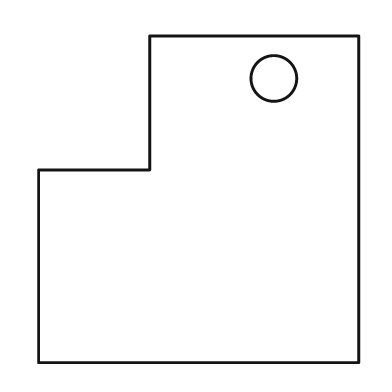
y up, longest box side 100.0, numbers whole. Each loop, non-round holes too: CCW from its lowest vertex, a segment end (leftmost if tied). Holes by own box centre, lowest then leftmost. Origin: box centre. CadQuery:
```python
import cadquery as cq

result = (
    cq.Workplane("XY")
    .moveTo(-49.0, -50.0)
    .lineTo(49.0, -50.0)
    .lineTo(49.0, 50.0)
    .lineTo(-15.0, 50.0)
    .lineTo(-15.0, 9.0)
    .lineTo(-49.0, 9.0)
    .close()
    .moveTo(23.0, 37.0)
    .circle(7.0)
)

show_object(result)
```